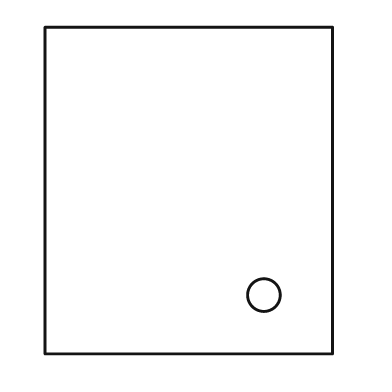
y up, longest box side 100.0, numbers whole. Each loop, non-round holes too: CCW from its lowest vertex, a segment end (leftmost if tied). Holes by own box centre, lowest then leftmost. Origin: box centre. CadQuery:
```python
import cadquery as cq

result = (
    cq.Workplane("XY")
    .moveTo(-44.0, -50.0)
    .lineTo(44.0, -50.0)
    .lineTo(44.0, 50.0)
    .lineTo(-44.0, 50.0)
    .close()
    .moveTo(23.0, -32.0)
    .circle(5.0)
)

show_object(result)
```